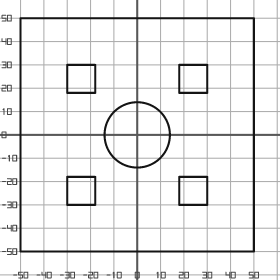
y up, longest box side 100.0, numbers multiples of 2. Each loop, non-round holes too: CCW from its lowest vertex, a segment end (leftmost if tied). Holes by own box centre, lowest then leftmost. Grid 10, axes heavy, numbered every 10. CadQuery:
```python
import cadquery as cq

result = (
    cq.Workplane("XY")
    .moveTo(-50.0, -50.0)
    .lineTo(50.0, -50.0)
    .lineTo(50.0, 50.0)
    .lineTo(-50.0, 50.0)
    .close()
    .moveTo(-30.0, -30.0)
    .lineTo(-18.0, -30.0)
    .lineTo(-18.0, -18.0)
    .lineTo(-30.0, -18.0)
    .close()
    .moveTo(18.0, -30.0)
    .lineTo(30.0, -30.0)
    .lineTo(30.0, -18.0)
    .lineTo(18.0, -18.0)
    .close()
    .moveTo(0.0, 0.0)
    .circle(14.0)
    .moveTo(-30.0, 18.0)
    .lineTo(-18.0, 18.0)
    .lineTo(-18.0, 30.0)
    .lineTo(-30.0, 30.0)
    .close()
    .moveTo(18.0, 18.0)
    .lineTo(30.0, 18.0)
    .lineTo(30.0, 30.0)
    .lineTo(18.0, 30.0)
    .close()
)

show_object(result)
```